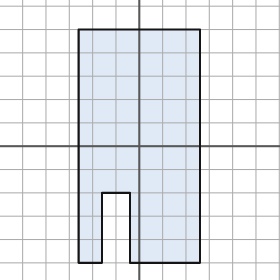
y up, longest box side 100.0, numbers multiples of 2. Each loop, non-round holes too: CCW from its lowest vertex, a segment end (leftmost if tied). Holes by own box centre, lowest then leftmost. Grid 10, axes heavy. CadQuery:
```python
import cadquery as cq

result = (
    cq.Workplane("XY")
    .moveTo(-26.0, -50.0)
    .lineTo(-16.0, -50.0)
    .lineTo(-16.0, -20.0)
    .lineTo(-4.0, -20.0)
    .lineTo(-4.0, -50.0)
    .lineTo(26.0, -50.0)
    .lineTo(26.0, 50.0)
    .lineTo(-26.0, 50.0)
    .close()
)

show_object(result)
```